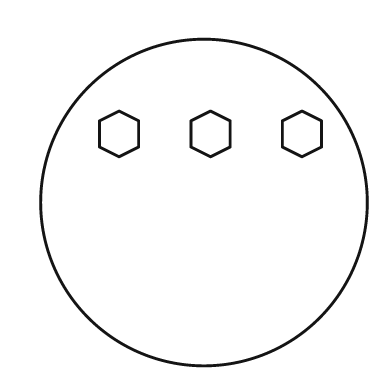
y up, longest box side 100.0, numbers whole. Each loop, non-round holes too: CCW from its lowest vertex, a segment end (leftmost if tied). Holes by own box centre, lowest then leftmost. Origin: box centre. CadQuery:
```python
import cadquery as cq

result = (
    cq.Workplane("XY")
    .moveTo(0.0, 0.0)
    .circle(50.0)
    .moveTo(-26.0, 14.0)
    .lineTo(-20.0, 17.0)
    .lineTo(-20.0, 25.0)
    .lineTo(-26.0, 28.0)
    .lineTo(-32.0, 25.0)
    .lineTo(-32.0, 17.0)
    .close()
    .moveTo(2.0, 14.0)
    .lineTo(8.0, 17.0)
    .lineTo(8.0, 25.0)
    .lineTo(2.0, 28.0)
    .lineTo(-4.0, 25.0)
    .lineTo(-4.0, 17.0)
    .close()
    .moveTo(30.0, 14.0)
    .lineTo(36.0, 17.0)
    .lineTo(36.0, 25.0)
    .lineTo(30.0, 28.0)
    .lineTo(24.0, 25.0)
    .lineTo(24.0, 17.0)
    .close()
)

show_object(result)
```